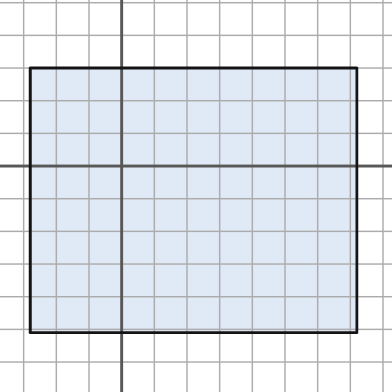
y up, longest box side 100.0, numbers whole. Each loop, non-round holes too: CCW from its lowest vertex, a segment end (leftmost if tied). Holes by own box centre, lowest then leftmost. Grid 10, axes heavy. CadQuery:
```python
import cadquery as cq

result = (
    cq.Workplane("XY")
    .moveTo(-28.0, -51.0)
    .lineTo(72.0, -51.0)
    .lineTo(72.0, 30.0)
    .lineTo(-28.0, 30.0)
    .close()
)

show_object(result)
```